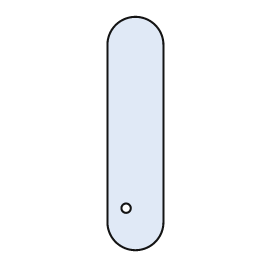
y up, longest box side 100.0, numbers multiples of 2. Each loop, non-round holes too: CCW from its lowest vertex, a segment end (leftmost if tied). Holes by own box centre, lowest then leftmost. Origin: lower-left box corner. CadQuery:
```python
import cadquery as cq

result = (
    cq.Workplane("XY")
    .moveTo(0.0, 12.0)
    .threePointArc((12.0, 0.0), (24.0, 12.0))
    .lineTo(24.0, 88.0)
    .threePointArc((12.0, 100.0), (0.0, 88.0))
    .close()
    .moveTo(8.0, 18.0)
    .circle(2.0)
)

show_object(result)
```